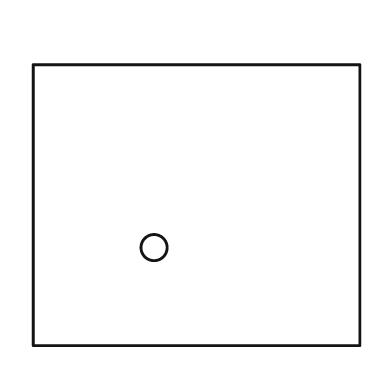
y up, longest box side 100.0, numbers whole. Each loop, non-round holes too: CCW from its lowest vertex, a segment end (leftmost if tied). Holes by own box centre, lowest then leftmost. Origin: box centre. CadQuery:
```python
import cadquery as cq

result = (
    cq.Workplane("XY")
    .moveTo(-50.0, -43.0)
    .lineTo(50.0, -43.0)
    .lineTo(50.0, 43.0)
    .lineTo(-50.0, 43.0)
    .close()
    .moveTo(-13.0, -13.0)
    .circle(4.0)
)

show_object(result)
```